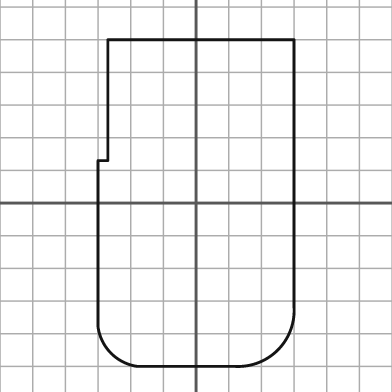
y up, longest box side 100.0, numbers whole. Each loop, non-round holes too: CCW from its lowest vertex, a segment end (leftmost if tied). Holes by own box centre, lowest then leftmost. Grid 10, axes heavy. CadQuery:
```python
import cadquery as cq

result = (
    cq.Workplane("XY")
    .moveTo(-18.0, -50.0)
    .lineTo(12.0, -50.0)
    .threePointArc((25.0, -45.0), (30.0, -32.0))
    .lineTo(30.0, 50.0)
    .lineTo(-27.0, 50.0)
    .lineTo(-27.0, 13.0)
    .lineTo(-30.0, 13.0)
    .lineTo(-30.0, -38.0)
    .threePointArc((-26.0, -46.0), (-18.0, -50.0))
    .close()
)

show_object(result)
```